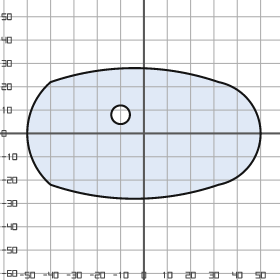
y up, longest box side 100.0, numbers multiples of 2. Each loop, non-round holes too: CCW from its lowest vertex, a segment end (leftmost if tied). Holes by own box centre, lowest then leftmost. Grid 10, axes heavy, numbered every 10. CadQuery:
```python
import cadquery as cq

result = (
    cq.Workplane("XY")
    .moveTo(-40.0, -22.0)
    .threePointArc((-4.0, -28.0), (32.0, -22.0))
    .threePointArc((50.0, 0.0), (32.0, 22.0))
    .threePointArc((-4.0, 28.0), (-40.0, 22.0))
    .threePointArc((-50.0, 0.0), (-40.0, -22.0))
    .close()
    .moveTo(-10.0, 8.0)
    .circle(4.0)
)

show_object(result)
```